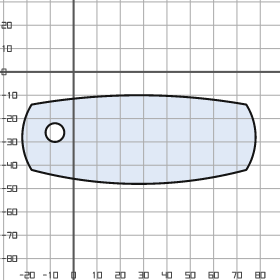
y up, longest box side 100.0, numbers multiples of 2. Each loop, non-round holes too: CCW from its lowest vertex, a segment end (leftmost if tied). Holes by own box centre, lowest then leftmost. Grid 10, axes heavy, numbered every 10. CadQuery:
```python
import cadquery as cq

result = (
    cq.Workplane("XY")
    .moveTo(-18.0, -42.0)
    .threePointArc((28.0, -48.0), (74.0, -42.0))
    .threePointArc((78.0, -28.0), (74.0, -14.0))
    .threePointArc((28.0, -10.0), (-18.0, -14.0))
    .threePointArc((-22.0, -28.0), (-18.0, -42.0))
    .close()
    .moveTo(-8.0, -26.0)
    .circle(4.0)
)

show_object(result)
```